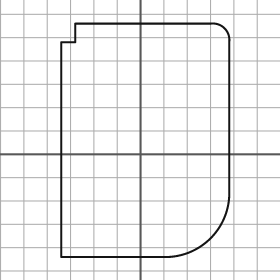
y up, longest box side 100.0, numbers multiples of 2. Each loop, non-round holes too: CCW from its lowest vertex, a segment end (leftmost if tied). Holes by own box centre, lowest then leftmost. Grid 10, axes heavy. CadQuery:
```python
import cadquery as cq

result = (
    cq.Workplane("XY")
    .moveTo(-34.0, -44.0)
    .lineTo(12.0, -44.0)
    .threePointArc((30.0, -36.0), (38.0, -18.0))
    .lineTo(38.0, 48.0)
    .threePointArc((36.0, 54.0), (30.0, 56.0))
    .lineTo(-28.0, 56.0)
    .lineTo(-28.0, 48.0)
    .lineTo(-34.0, 48.0)
    .close()
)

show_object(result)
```